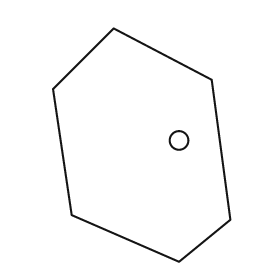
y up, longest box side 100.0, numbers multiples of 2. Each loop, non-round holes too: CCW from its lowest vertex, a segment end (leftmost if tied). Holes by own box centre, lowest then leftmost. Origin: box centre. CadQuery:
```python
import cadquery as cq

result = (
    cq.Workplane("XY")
    .moveTo(16.0, -50.0)
    .lineTo(38.0, -32.0)
    .lineTo(30.0, 28.0)
    .lineTo(-12.0, 50.0)
    .lineTo(-38.0, 24.0)
    .lineTo(-30.0, -30.0)
    .close()
    .moveTo(16.0, 2.0)
    .circle(4.0)
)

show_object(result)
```